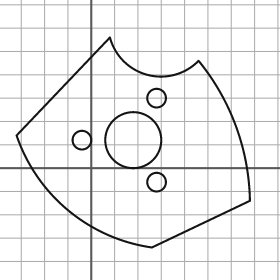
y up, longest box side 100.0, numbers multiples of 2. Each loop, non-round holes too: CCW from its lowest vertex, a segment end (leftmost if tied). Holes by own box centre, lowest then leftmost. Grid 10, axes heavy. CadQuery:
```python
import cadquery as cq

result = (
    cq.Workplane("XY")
    .moveTo(26.0, -34.0)
    .lineTo(68.0, -14.0)
    .threePointArc((62.0, 18.0), (46.0, 46.0))
    .threePointArc((24.0, 40.0), (8.0, 56.0))
    .lineTo(-32.0, 14.0)
    .threePointArc((-10.0, -18.0), (26.0, -34.0))
    .close()
    .moveTo(28.0, -6.0)
    .circle(4.0)
    .moveTo(-4.0, 12.0)
    .circle(4.0)
    .moveTo(18.0, 12.0)
    .circle(12.0)
    .moveTo(28.0, 30.0)
    .circle(4.0)
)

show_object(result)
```